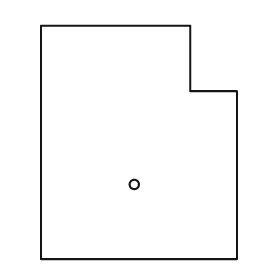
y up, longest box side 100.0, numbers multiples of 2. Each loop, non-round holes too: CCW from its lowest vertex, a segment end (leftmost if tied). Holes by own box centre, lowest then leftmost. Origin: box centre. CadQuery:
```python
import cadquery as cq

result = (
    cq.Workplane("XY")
    .moveTo(-42.0, -50.0)
    .lineTo(42.0, -50.0)
    .lineTo(42.0, 22.0)
    .lineTo(22.0, 22.0)
    .lineTo(22.0, 50.0)
    .lineTo(-42.0, 50.0)
    .close()
    .moveTo(-2.0, -18.0)
    .circle(2.0)
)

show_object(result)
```